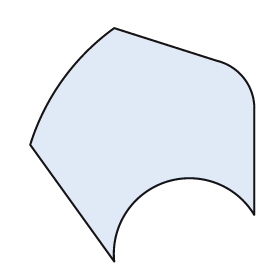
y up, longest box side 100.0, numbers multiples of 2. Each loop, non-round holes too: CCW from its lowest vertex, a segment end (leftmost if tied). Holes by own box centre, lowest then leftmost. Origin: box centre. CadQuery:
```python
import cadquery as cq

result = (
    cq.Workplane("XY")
    .moveTo(-12.0, -50.0)
    .threePointArc((10.0, -16.0), (48.0, -30.0))
    .lineTo(48.0, 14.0)
    .threePointArc((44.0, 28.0), (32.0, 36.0))
    .lineTo(-12.0, 50.0)
    .threePointArc((-34.0, 28.0), (-48.0, 0.0))
    .close()
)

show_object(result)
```